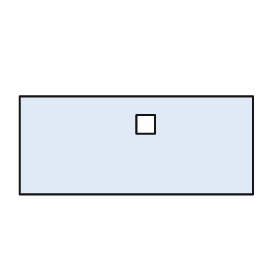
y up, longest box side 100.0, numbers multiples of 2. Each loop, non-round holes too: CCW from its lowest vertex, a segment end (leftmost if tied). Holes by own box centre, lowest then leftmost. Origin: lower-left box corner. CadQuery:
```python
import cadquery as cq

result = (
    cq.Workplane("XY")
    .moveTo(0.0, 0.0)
    .lineTo(100.0, 0.0)
    .lineTo(100.0, 42.0)
    .lineTo(0.0, 42.0)
    .close()
    .moveTo(50.0, 26.0)
    .lineTo(58.0, 26.0)
    .lineTo(58.0, 34.0)
    .lineTo(50.0, 34.0)
    .close()
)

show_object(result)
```